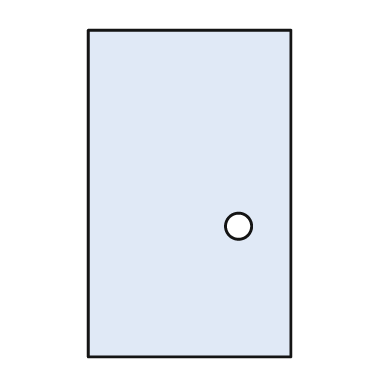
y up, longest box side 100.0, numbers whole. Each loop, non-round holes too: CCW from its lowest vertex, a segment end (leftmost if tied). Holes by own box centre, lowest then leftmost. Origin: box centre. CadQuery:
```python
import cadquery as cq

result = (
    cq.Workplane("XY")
    .moveTo(-31.0, -50.0)
    .lineTo(31.0, -50.0)
    .lineTo(31.0, 50.0)
    .lineTo(-31.0, 50.0)
    .close()
    .moveTo(15.0, -10.0)
    .circle(4.0)
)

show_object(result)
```